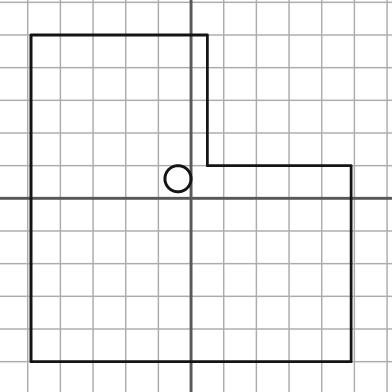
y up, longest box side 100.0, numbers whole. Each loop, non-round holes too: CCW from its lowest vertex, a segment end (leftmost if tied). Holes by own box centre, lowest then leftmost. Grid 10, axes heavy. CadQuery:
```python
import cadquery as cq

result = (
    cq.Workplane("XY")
    .moveTo(-49.0, -50.0)
    .lineTo(49.0, -50.0)
    .lineTo(49.0, 10.0)
    .lineTo(5.0, 10.0)
    .lineTo(5.0, 50.0)
    .lineTo(-49.0, 50.0)
    .close()
    .moveTo(-4.0, 6.0)
    .circle(4.0)
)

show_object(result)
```